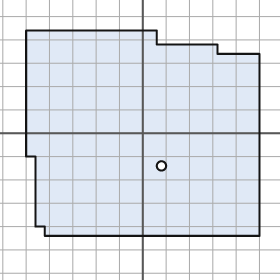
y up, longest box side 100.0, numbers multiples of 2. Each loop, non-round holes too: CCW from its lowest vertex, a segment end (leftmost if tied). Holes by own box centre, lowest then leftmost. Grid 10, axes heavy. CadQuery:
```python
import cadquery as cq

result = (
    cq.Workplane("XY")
    .moveTo(-42.0, -44.0)
    .lineTo(50.0, -44.0)
    .lineTo(50.0, 34.0)
    .lineTo(32.0, 34.0)
    .lineTo(32.0, 38.0)
    .lineTo(6.0, 38.0)
    .lineTo(6.0, 44.0)
    .lineTo(-50.0, 44.0)
    .lineTo(-50.0, -10.0)
    .lineTo(-46.0, -10.0)
    .lineTo(-46.0, -40.0)
    .lineTo(-42.0, -40.0)
    .close()
    .moveTo(8.0, -14.0)
    .circle(2.0)
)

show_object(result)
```